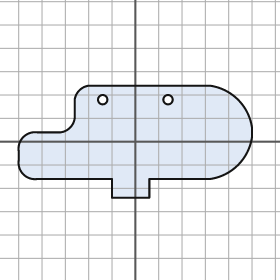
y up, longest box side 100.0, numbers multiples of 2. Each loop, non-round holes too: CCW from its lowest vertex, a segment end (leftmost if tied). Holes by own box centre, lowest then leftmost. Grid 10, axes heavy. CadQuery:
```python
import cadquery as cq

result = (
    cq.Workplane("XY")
    .moveTo(-10.0, -24.0)
    .lineTo(6.0, -24.0)
    .lineTo(6.0, -16.0)
    .lineTo(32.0, -16.0)
    .threePointArc((44.0, -10.0), (50.0, 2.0))
    .lineTo(50.0, 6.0)
    .threePointArc((44.0, 18.0), (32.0, 24.0))
    .lineTo(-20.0, 24.0)
    .threePointArc((-24.0, 22.0), (-26.0, 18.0))
    .lineTo(-26.0, 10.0)
    .threePointArc((-28.0, 6.0), (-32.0, 4.0))
    .lineTo(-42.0, 4.0)
    .threePointArc((-48.0, 2.0), (-50.0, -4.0))
    .lineTo(-50.0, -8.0)
    .threePointArc((-48.0, -14.0), (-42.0, -16.0))
    .lineTo(-10.0, -16.0)
    .close()
    .moveTo(-14.0, 18.0)
    .circle(2.0)
    .moveTo(14.0, 18.0)
    .circle(2.0)
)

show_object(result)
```